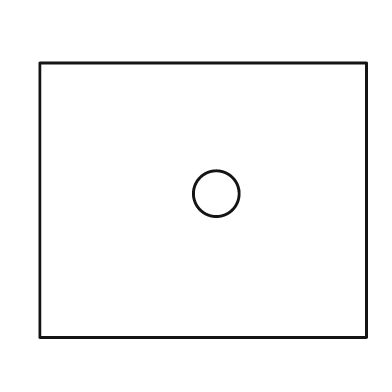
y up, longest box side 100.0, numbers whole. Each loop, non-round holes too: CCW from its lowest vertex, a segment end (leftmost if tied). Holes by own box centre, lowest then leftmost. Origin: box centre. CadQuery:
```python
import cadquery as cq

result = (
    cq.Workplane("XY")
    .moveTo(-50.0, -42.0)
    .lineTo(50.0, -42.0)
    .lineTo(50.0, 42.0)
    .lineTo(-50.0, 42.0)
    .close()
    .moveTo(4.0, 2.0)
    .circle(7.0)
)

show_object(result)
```